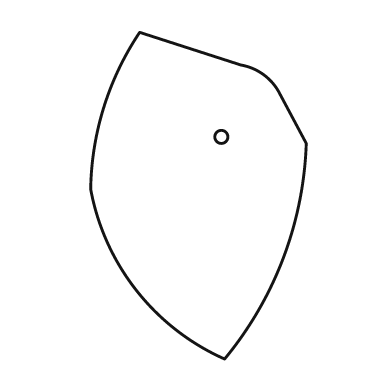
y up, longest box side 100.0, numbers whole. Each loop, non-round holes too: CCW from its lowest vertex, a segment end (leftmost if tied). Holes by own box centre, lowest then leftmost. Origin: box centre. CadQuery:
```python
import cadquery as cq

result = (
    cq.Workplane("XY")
    .moveTo(8.0, -50.0)
    .threePointArc((26.0, -19.0), (33.0, 16.0))
    .lineTo(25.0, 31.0)
    .threePointArc((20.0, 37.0), (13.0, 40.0))
    .lineTo(-18.0, 50.0)
    .threePointArc((-29.0, 27.0), (-33.0, 2.0))
    .threePointArc((-19.0, -29.0), (8.0, -50.0))
    .close()
    .moveTo(7.0, 18.0)
    .circle(2.0)
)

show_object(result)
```